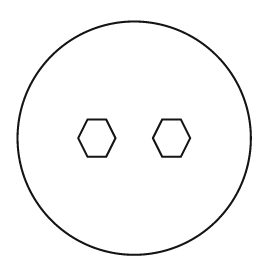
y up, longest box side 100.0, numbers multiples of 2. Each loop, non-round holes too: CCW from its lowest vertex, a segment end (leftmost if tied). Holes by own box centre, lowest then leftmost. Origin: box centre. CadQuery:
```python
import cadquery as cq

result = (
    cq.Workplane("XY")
    .moveTo(0.0, 0.0)
    .circle(50.0)
    .moveTo(-20.0, -8.0)
    .lineTo(-12.0, -8.0)
    .lineTo(-8.0, 0.0)
    .lineTo(-12.0, 8.0)
    .lineTo(-20.0, 8.0)
    .lineTo(-24.0, 0.0)
    .close()
    .moveTo(12.0, -8.0)
    .lineTo(20.0, -8.0)
    .lineTo(24.0, 0.0)
    .lineTo(20.0, 8.0)
    .lineTo(12.0, 8.0)
    .lineTo(8.0, 0.0)
    .close()
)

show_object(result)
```